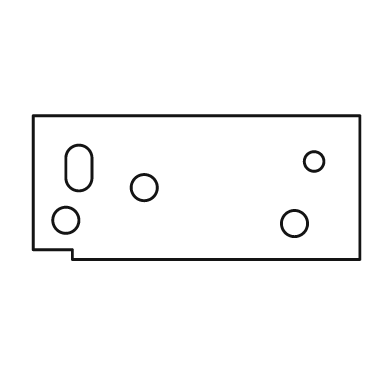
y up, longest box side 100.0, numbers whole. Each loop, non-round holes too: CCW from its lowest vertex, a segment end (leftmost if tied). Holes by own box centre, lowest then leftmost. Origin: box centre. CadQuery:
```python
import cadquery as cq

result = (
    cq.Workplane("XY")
    .moveTo(-38.0, -22.0)
    .lineTo(50.0, -22.0)
    .lineTo(50.0, 22.0)
    .lineTo(-50.0, 22.0)
    .lineTo(-50.0, -19.0)
    .lineTo(-38.0, -19.0)
    .close()
    .moveTo(30.0, -11.0)
    .circle(4.0)
    .moveTo(-40.0, -10.0)
    .circle(4.0)
    .moveTo(-16.0, 0.0)
    .circle(4.0)
    .moveTo(-40.0, 3.0)
    .threePointArc((-36.0, -1.0), (-32.0, 3.0))
    .lineTo(-32.0, 9.0)
    .threePointArc((-36.0, 13.0), (-40.0, 9.0))
    .close()
    .moveTo(36.0, 8.0)
    .circle(3.0)
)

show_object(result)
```